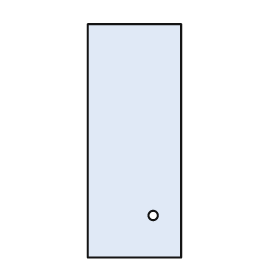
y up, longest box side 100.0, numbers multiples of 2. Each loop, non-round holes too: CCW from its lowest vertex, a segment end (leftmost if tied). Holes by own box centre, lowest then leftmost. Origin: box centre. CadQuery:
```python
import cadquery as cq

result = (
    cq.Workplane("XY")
    .moveTo(-20.0, -50.0)
    .lineTo(20.0, -50.0)
    .lineTo(20.0, 50.0)
    .lineTo(-20.0, 50.0)
    .close()
    .moveTo(8.0, -32.0)
    .circle(2.0)
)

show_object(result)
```